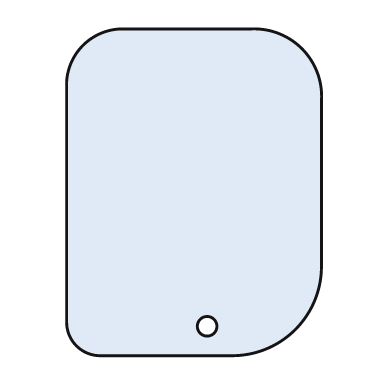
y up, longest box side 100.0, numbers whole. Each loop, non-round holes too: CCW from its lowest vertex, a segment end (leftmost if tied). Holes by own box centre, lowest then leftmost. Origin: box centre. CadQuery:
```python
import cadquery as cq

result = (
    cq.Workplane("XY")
    .moveTo(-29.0, -50.0)
    .lineTo(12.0, -50.0)
    .threePointArc((31.0, -42.0), (39.0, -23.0))
    .lineTo(39.0, 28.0)
    .threePointArc((33.0, 44.0), (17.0, 50.0))
    .lineTo(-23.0, 50.0)
    .threePointArc((-34.0, 45.0), (-39.0, 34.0))
    .lineTo(-39.0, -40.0)
    .threePointArc((-36.0, -47.0), (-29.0, -50.0))
    .close()
    .moveTo(4.0, -41.0)
    .circle(3.0)
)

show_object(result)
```